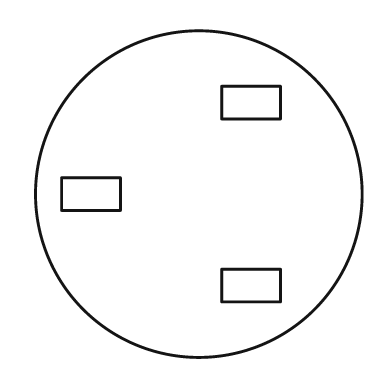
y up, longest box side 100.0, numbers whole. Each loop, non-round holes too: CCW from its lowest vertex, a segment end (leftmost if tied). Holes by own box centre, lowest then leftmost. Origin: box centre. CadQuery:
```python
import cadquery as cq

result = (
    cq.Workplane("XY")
    .moveTo(0.0, 0.0)
    .circle(50.0)
    .moveTo(7.0, -33.0)
    .lineTo(25.0, -33.0)
    .lineTo(25.0, -23.0)
    .lineTo(7.0, -23.0)
    .close()
    .moveTo(-42.0, -5.0)
    .lineTo(-24.0, -5.0)
    .lineTo(-24.0, 5.0)
    .lineTo(-42.0, 5.0)
    .close()
    .moveTo(7.0, 23.0)
    .lineTo(25.0, 23.0)
    .lineTo(25.0, 33.0)
    .lineTo(7.0, 33.0)
    .close()
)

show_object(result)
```